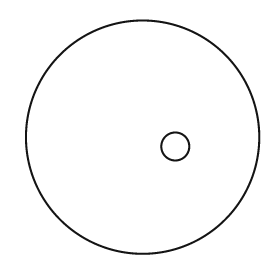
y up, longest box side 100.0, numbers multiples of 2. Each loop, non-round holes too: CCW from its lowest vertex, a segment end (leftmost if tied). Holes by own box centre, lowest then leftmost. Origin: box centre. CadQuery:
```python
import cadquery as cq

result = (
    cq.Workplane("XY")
    .moveTo(0.0, 0.0)
    .circle(50.0)
    .moveTo(14.0, -4.0)
    .circle(6.0)
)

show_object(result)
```